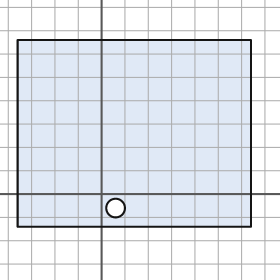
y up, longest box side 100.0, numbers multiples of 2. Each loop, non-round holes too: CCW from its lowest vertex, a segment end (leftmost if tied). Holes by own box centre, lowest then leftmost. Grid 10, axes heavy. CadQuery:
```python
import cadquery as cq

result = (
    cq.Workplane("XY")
    .moveTo(-36.0, -14.0)
    .lineTo(64.0, -14.0)
    .lineTo(64.0, 66.0)
    .lineTo(-36.0, 66.0)
    .close()
    .moveTo(6.0, -6.0)
    .circle(4.0)
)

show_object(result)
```